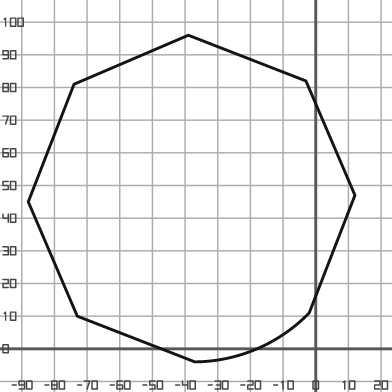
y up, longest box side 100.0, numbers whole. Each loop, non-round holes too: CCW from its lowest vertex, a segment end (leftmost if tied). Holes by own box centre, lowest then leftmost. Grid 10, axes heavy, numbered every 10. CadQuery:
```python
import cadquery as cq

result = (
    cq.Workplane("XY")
    .moveTo(-37.0, -4.0)
    .threePointArc((-18.0, 0.0), (-2.0, 11.0))
    .lineTo(12.0, 47.0)
    .lineTo(-3.0, 82.0)
    .lineTo(-39.0, 96.0)
    .lineTo(-74.0, 81.0)
    .lineTo(-88.0, 45.0)
    .lineTo(-73.0, 10.0)
    .close()
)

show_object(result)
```